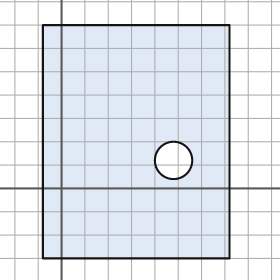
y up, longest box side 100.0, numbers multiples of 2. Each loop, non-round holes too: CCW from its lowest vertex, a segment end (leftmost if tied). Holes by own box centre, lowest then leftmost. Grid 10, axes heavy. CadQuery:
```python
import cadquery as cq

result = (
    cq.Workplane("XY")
    .moveTo(-8.0, -30.0)
    .lineTo(72.0, -30.0)
    .lineTo(72.0, 70.0)
    .lineTo(-8.0, 70.0)
    .close()
    .moveTo(48.0, 12.0)
    .circle(8.0)
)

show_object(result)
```